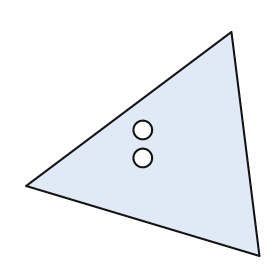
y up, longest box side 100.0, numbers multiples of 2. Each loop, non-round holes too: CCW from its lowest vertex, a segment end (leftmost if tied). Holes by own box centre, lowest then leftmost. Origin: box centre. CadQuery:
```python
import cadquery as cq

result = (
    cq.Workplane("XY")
    .moveTo(50.0, -48.0)
    .lineTo(38.0, 48.0)
    .lineTo(-50.0, -18.0)
    .close()
    .moveTo(0.0, -6.0)
    .circle(4.0)
    .moveTo(0.0, 6.0)
    .circle(4.0)
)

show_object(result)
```